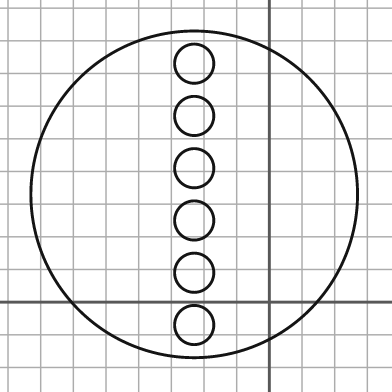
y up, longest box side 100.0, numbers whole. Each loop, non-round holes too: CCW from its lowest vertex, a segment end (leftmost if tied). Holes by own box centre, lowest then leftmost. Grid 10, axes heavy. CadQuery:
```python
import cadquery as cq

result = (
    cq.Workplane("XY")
    .moveTo(-23.0, 33.0)
    .circle(50.0)
    .moveTo(-23.0, -7.0)
    .circle(6.0)
    .moveTo(-23.0, 9.0)
    .circle(6.0)
    .moveTo(-23.0, 25.0)
    .circle(6.0)
    .moveTo(-23.0, 41.0)
    .circle(6.0)
    .moveTo(-23.0, 57.0)
    .circle(6.0)
    .moveTo(-23.0, 73.0)
    .circle(6.0)
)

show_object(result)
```